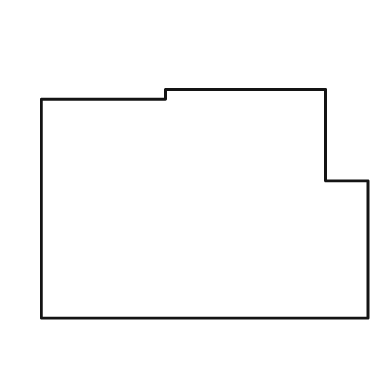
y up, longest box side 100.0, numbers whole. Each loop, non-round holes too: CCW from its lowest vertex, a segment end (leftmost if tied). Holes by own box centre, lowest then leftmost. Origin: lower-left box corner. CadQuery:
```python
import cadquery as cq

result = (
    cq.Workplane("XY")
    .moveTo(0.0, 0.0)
    .lineTo(100.0, 0.0)
    .lineTo(100.0, 42.0)
    .lineTo(87.0, 42.0)
    .lineTo(87.0, 70.0)
    .lineTo(38.0, 70.0)
    .lineTo(38.0, 67.0)
    .lineTo(0.0, 67.0)
    .close()
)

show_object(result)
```